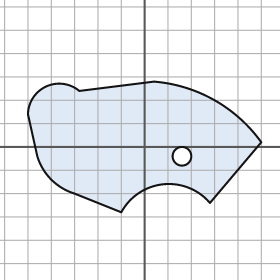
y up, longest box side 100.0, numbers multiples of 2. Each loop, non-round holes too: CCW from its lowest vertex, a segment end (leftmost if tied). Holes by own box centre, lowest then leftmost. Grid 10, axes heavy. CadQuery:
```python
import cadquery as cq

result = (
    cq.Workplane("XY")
    .moveTo(-10.0, -28.0)
    .threePointArc((8.0, -16.0), (28.0, -24.0))
    .lineTo(50.0, 2.0)
    .threePointArc((30.0, 20.0), (4.0, 28.0))
    .lineTo(-28.0, 24.0)
    .threePointArc((-42.0, 26.0), (-50.0, 14.0))
    .lineTo(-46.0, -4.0)
    .threePointArc((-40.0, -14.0), (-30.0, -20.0))
    .close()
    .moveTo(16.0, -4.0)
    .circle(4.0)
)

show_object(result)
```